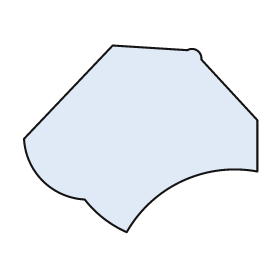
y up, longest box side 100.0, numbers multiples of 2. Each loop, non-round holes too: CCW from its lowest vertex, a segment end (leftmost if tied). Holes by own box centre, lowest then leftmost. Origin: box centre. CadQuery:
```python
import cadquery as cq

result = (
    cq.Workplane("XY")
    .moveTo(-6.0, -40.0)
    .threePointArc((18.0, -18.0), (50.0, -14.0))
    .lineTo(50.0, 8.0)
    .lineTo(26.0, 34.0)
    .threePointArc((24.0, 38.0), (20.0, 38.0))
    .lineTo(-12.0, 40.0)
    .lineTo(-50.0, 0.0)
    .threePointArc((-42.0, -18.0), (-24.0, -26.0))
    .threePointArc((-16.0, -34.0), (-6.0, -40.0))
    .close()
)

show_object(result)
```